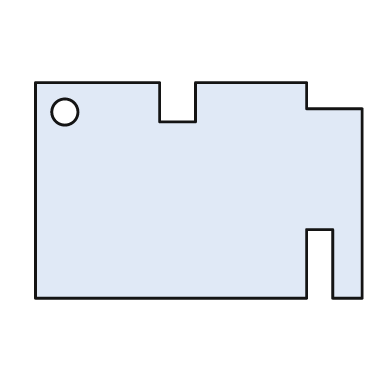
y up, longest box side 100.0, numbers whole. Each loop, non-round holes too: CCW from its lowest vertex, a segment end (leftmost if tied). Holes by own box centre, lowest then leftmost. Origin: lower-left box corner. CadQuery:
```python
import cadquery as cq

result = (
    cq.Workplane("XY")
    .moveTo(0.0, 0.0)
    .lineTo(83.0, 0.0)
    .lineTo(83.0, 21.0)
    .lineTo(91.0, 21.0)
    .lineTo(91.0, 0.0)
    .lineTo(100.0, 0.0)
    .lineTo(100.0, 58.0)
    .lineTo(83.0, 58.0)
    .lineTo(83.0, 66.0)
    .lineTo(49.0, 66.0)
    .lineTo(49.0, 54.0)
    .lineTo(38.0, 54.0)
    .lineTo(38.0, 66.0)
    .lineTo(0.0, 66.0)
    .close()
    .moveTo(9.0, 57.0)
    .circle(4.0)
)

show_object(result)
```